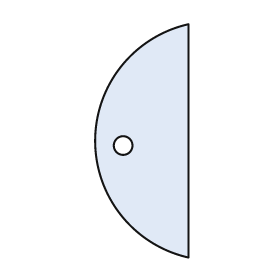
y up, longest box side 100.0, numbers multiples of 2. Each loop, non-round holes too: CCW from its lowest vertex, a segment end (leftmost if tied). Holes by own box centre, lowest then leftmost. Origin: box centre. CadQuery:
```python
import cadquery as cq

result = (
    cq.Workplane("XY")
    .moveTo(20.0, -50.0)
    .lineTo(20.0, 50.0)
    .threePointArc((-20.0, 0.0), (20.0, -50.0))
    .close()
    .moveTo(-8.0, -2.0)
    .circle(4.0)
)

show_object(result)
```